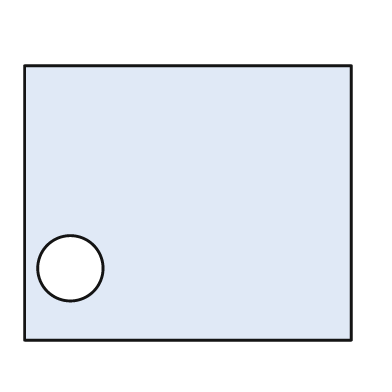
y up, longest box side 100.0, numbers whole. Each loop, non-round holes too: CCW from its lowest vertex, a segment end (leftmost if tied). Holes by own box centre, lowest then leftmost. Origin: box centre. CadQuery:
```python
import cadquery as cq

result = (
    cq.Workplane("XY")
    .moveTo(-50.0, -42.0)
    .lineTo(50.0, -42.0)
    .lineTo(50.0, 42.0)
    .lineTo(-50.0, 42.0)
    .close()
    .moveTo(-36.0, -20.0)
    .circle(10.0)
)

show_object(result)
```